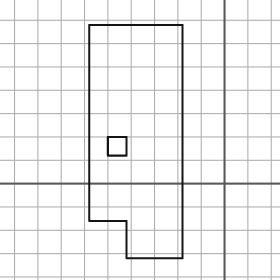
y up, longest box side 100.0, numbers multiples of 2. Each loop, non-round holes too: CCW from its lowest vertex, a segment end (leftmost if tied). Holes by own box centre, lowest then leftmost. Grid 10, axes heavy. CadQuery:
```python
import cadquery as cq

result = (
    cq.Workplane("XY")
    .moveTo(-42.0, -32.0)
    .lineTo(-18.0, -32.0)
    .lineTo(-18.0, 68.0)
    .lineTo(-58.0, 68.0)
    .lineTo(-58.0, -16.0)
    .lineTo(-42.0, -16.0)
    .close()
    .moveTo(-50.0, 12.0)
    .lineTo(-42.0, 12.0)
    .lineTo(-42.0, 20.0)
    .lineTo(-50.0, 20.0)
    .close()
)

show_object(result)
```